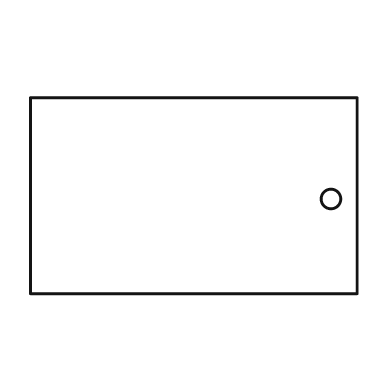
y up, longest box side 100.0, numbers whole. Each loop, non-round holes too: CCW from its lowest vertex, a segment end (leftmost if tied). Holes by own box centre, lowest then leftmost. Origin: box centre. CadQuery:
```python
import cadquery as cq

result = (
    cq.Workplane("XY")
    .moveTo(-50.0, -30.0)
    .lineTo(50.0, -30.0)
    .lineTo(50.0, 30.0)
    .lineTo(-50.0, 30.0)
    .close()
    .moveTo(42.0, -1.0)
    .circle(3.0)
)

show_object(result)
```